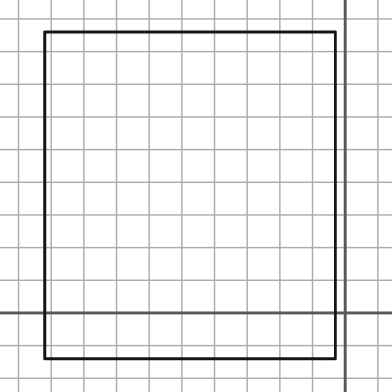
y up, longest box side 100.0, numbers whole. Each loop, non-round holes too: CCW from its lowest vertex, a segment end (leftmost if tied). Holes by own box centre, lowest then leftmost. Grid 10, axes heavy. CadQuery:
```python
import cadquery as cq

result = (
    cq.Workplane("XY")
    .moveTo(-92.0, -14.0)
    .lineTo(-3.0, -14.0)
    .lineTo(-3.0, 86.0)
    .lineTo(-92.0, 86.0)
    .close()
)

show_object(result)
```